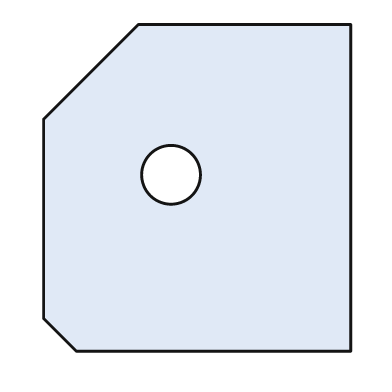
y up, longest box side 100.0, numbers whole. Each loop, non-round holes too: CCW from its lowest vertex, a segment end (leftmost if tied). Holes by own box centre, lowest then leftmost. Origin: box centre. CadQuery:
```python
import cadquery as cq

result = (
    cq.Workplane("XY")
    .moveTo(-37.0, -50.0)
    .lineTo(47.0, -50.0)
    .lineTo(47.0, 50.0)
    .lineTo(-18.0, 50.0)
    .lineTo(-47.0, 21.0)
    .lineTo(-47.0, -40.0)
    .close()
    .moveTo(-8.0, 4.0)
    .circle(9.0)
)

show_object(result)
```